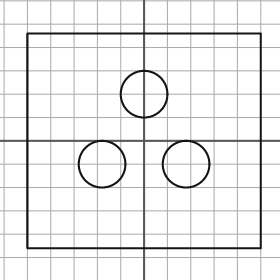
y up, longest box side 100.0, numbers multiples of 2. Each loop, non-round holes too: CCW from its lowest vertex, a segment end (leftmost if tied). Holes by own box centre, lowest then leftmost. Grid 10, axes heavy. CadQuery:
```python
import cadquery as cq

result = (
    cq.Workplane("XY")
    .moveTo(-50.0, -46.0)
    .lineTo(50.0, -46.0)
    .lineTo(50.0, 46.0)
    .lineTo(-50.0, 46.0)
    .close()
    .moveTo(-18.0, -10.0)
    .circle(10.0)
    .moveTo(18.0, -10.0)
    .circle(10.0)
    .moveTo(0.0, 20.0)
    .circle(10.0)
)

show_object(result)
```